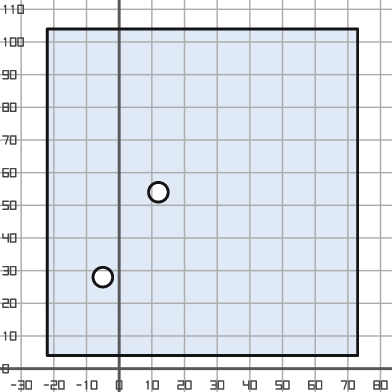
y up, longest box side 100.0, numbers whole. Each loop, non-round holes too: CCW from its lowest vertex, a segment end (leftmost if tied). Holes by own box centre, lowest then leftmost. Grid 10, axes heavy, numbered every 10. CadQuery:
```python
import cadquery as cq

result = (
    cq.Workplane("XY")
    .moveTo(-22.0, 4.0)
    .lineTo(73.0, 4.0)
    .lineTo(73.0, 104.0)
    .lineTo(-22.0, 104.0)
    .close()
    .moveTo(-5.0, 28.0)
    .circle(3.0)
    .moveTo(12.0, 54.0)
    .circle(3.0)
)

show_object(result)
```